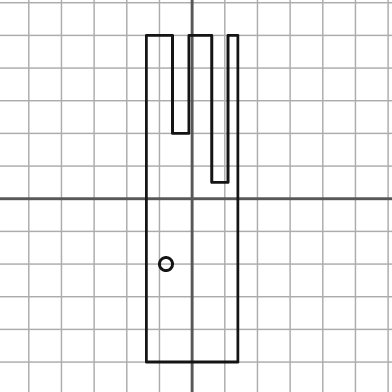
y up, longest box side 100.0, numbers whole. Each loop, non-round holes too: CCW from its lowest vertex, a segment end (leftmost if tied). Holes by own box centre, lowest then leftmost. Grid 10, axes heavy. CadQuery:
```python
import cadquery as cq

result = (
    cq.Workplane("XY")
    .moveTo(-14.0, -50.0)
    .lineTo(14.0, -50.0)
    .lineTo(14.0, 50.0)
    .lineTo(11.0, 50.0)
    .lineTo(11.0, 5.0)
    .lineTo(6.0, 5.0)
    .lineTo(6.0, 50.0)
    .lineTo(-1.0, 50.0)
    .lineTo(-1.0, 20.0)
    .lineTo(-6.0, 20.0)
    .lineTo(-6.0, 50.0)
    .lineTo(-14.0, 50.0)
    .close()
    .moveTo(-8.0, -20.0)
    .circle(2.0)
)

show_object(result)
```